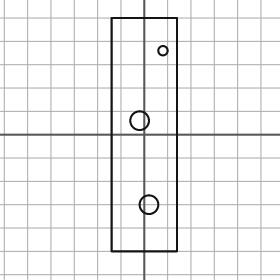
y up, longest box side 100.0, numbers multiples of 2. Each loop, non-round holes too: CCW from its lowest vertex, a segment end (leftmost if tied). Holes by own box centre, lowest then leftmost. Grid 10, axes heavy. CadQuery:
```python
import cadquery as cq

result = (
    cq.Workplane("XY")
    .moveTo(-14.0, -50.0)
    .lineTo(14.0, -50.0)
    .lineTo(14.0, 50.0)
    .lineTo(-14.0, 50.0)
    .close()
    .moveTo(2.0, -30.0)
    .circle(4.0)
    .moveTo(-2.0, 6.0)
    .circle(4.0)
    .moveTo(8.0, 36.0)
    .circle(2.0)
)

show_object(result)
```